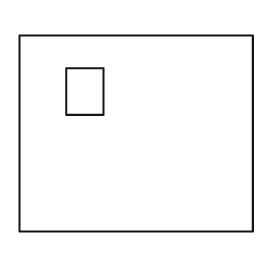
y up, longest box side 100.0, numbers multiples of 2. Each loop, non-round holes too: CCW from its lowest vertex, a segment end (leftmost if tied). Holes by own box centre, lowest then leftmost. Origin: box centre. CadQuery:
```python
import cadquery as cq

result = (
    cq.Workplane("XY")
    .moveTo(-50.0, -42.0)
    .lineTo(50.0, -42.0)
    .lineTo(50.0, 42.0)
    .lineTo(-50.0, 42.0)
    .close()
    .moveTo(-30.0, 8.0)
    .lineTo(-14.0, 8.0)
    .lineTo(-14.0, 28.0)
    .lineTo(-30.0, 28.0)
    .close()
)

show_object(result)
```